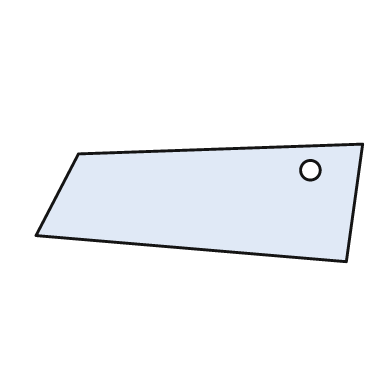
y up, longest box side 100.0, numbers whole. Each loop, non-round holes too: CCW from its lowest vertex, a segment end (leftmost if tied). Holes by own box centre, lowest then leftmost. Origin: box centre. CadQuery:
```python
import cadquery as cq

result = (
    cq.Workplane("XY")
    .moveTo(45.0, -18.0)
    .lineTo(50.0, 18.0)
    .lineTo(-37.0, 15.0)
    .lineTo(-50.0, -10.0)
    .close()
    .moveTo(34.0, 10.0)
    .circle(3.0)
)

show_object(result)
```